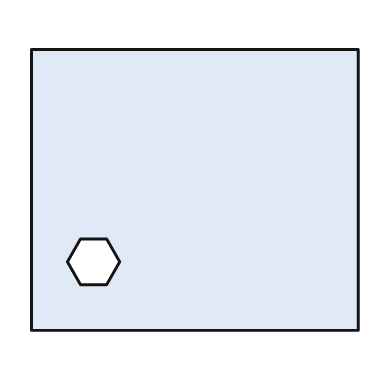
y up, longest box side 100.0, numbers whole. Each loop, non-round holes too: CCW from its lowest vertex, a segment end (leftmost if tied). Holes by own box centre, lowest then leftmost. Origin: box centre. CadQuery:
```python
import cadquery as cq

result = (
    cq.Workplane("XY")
    .moveTo(-50.0, -43.0)
    .lineTo(50.0, -43.0)
    .lineTo(50.0, 43.0)
    .lineTo(-50.0, 43.0)
    .close()
    .moveTo(-35.0, -29.0)
    .lineTo(-27.0, -29.0)
    .lineTo(-23.0, -22.0)
    .lineTo(-27.0, -15.0)
    .lineTo(-35.0, -15.0)
    .lineTo(-39.0, -22.0)
    .close()
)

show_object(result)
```